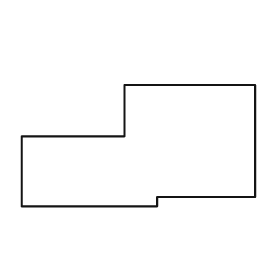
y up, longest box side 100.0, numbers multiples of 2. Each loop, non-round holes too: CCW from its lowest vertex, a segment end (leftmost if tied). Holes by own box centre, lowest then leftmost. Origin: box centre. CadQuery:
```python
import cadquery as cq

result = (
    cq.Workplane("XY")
    .moveTo(-50.0, -26.0)
    .lineTo(8.0, -26.0)
    .lineTo(8.0, -22.0)
    .lineTo(50.0, -22.0)
    .lineTo(50.0, 26.0)
    .lineTo(-6.0, 26.0)
    .lineTo(-6.0, 4.0)
    .lineTo(-50.0, 4.0)
    .close()
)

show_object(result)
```